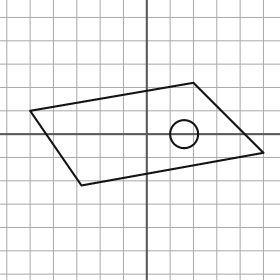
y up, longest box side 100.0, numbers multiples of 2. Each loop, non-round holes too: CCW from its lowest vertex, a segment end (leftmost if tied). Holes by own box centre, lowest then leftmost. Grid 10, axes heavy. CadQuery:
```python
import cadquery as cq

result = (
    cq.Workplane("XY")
    .moveTo(-28.0, -22.0)
    .lineTo(50.0, -8.0)
    .lineTo(20.0, 22.0)
    .lineTo(-50.0, 10.0)
    .close()
    .moveTo(16.0, 0.0)
    .circle(6.0)
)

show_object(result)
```